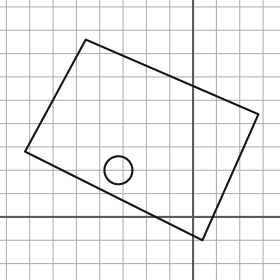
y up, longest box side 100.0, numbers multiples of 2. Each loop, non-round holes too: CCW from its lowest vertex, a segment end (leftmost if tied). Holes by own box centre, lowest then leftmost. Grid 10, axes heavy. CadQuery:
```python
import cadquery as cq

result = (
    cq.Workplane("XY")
    .moveTo(4.0, -10.0)
    .lineTo(28.0, 44.0)
    .lineTo(-46.0, 76.0)
    .lineTo(-72.0, 28.0)
    .close()
    .moveTo(-32.0, 20.0)
    .circle(6.0)
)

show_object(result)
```